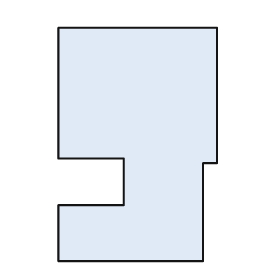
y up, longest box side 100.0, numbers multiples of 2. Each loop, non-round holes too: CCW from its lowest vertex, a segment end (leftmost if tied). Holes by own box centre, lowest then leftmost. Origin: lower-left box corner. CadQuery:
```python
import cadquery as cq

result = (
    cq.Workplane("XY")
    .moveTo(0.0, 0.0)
    .lineTo(62.0, 0.0)
    .lineTo(62.0, 42.0)
    .lineTo(68.0, 42.0)
    .lineTo(68.0, 100.0)
    .lineTo(0.0, 100.0)
    .lineTo(0.0, 44.0)
    .lineTo(28.0, 44.0)
    .lineTo(28.0, 24.0)
    .lineTo(0.0, 24.0)
    .close()
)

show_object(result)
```